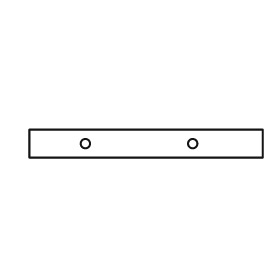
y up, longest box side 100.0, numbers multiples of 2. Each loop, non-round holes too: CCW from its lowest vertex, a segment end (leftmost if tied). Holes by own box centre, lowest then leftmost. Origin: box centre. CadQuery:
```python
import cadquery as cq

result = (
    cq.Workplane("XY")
    .moveTo(-50.0, -6.0)
    .lineTo(50.0, -6.0)
    .lineTo(50.0, 6.0)
    .lineTo(-50.0, 6.0)
    .close()
    .moveTo(-26.0, 0.0)
    .circle(2.0)
    .moveTo(20.0, 0.0)
    .circle(2.0)
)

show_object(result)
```